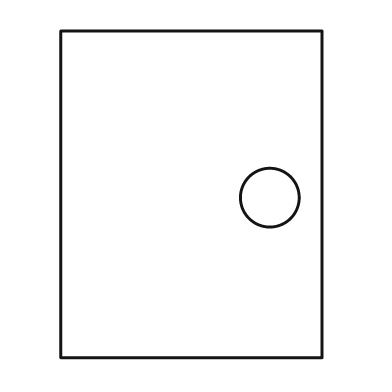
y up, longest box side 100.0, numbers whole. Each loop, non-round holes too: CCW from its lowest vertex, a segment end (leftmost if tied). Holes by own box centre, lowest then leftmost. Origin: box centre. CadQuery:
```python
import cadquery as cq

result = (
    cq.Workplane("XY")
    .moveTo(-40.0, -50.0)
    .lineTo(40.0, -50.0)
    .lineTo(40.0, 50.0)
    .lineTo(-40.0, 50.0)
    .close()
    .moveTo(24.0, -1.0)
    .circle(9.0)
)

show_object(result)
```